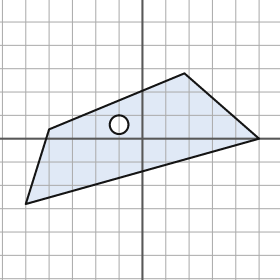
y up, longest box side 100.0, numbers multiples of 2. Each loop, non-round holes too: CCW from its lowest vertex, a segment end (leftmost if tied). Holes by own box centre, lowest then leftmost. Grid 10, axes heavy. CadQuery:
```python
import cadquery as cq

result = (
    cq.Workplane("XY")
    .moveTo(-50.0, -28.0)
    .lineTo(50.0, 0.0)
    .lineTo(18.0, 28.0)
    .lineTo(-40.0, 4.0)
    .close()
    .moveTo(-10.0, 6.0)
    .circle(4.0)
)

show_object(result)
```